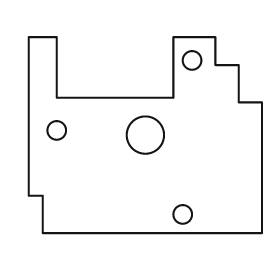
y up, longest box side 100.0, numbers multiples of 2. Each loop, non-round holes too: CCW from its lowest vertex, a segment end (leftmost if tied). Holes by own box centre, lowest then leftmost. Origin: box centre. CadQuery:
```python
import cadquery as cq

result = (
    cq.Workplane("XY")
    .moveTo(-44.0, -42.0)
    .lineTo(50.0, -42.0)
    .lineTo(50.0, 14.0)
    .lineTo(40.0, 14.0)
    .lineTo(40.0, 30.0)
    .lineTo(30.0, 30.0)
    .lineTo(30.0, 42.0)
    .lineTo(12.0, 42.0)
    .lineTo(12.0, 16.0)
    .lineTo(-38.0, 16.0)
    .lineTo(-38.0, 42.0)
    .lineTo(-50.0, 42.0)
    .lineTo(-50.0, -26.0)
    .lineTo(-44.0, -26.0)
    .close()
    .moveTo(16.0, -34.0)
    .circle(4.0)
    .moveTo(0.0, 0.0)
    .circle(8.0)
    .moveTo(-38.0, 2.0)
    .circle(4.0)
    .moveTo(20.0, 32.0)
    .circle(4.0)
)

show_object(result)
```